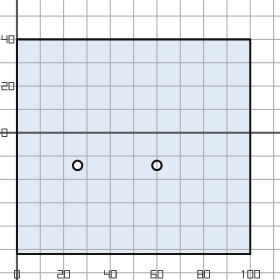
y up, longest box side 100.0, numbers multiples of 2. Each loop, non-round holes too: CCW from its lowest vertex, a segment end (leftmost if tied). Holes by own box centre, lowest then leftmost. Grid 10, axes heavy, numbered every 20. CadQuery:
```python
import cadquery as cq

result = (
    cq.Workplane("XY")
    .moveTo(0.0, -52.0)
    .lineTo(100.0, -52.0)
    .lineTo(100.0, 40.0)
    .lineTo(0.0, 40.0)
    .close()
    .moveTo(26.0, -14.0)
    .circle(2.0)
    .moveTo(60.0, -14.0)
    .circle(2.0)
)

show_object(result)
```